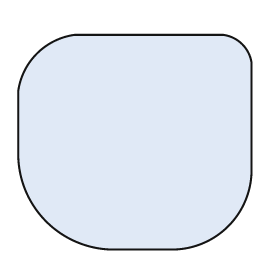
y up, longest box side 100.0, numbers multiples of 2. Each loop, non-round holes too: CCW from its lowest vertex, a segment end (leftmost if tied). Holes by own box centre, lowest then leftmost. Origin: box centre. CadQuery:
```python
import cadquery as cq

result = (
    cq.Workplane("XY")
    .moveTo(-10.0, -46.0)
    .lineTo(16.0, -46.0)
    .threePointArc((40.0, -36.0), (50.0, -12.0))
    .lineTo(50.0, 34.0)
    .threePointArc((46.0, 42.0), (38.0, 46.0))
    .lineTo(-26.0, 46.0)
    .threePointArc((-42.0, 38.0), (-50.0, 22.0))
    .lineTo(-50.0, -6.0)
    .threePointArc((-38.0, -34.0), (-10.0, -46.0))
    .close()
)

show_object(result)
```